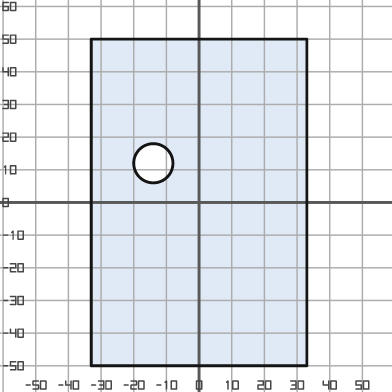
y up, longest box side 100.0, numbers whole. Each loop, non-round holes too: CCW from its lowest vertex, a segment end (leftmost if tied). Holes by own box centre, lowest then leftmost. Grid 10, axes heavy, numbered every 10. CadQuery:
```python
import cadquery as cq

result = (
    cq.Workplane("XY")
    .moveTo(-33.0, -50.0)
    .lineTo(33.0, -50.0)
    .lineTo(33.0, 50.0)
    .lineTo(-33.0, 50.0)
    .close()
    .moveTo(-14.0, 12.0)
    .circle(6.0)
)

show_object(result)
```